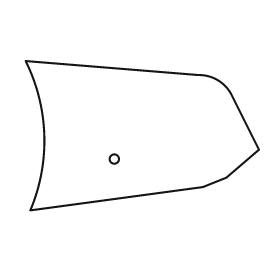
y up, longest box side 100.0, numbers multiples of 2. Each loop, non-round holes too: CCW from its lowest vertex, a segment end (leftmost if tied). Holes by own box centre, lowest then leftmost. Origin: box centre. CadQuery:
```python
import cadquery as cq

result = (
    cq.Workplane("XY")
    .moveTo(-48.0, -32.0)
    .lineTo(26.0, -22.0)
    .lineTo(36.0, -18.0)
    .lineTo(50.0, -6.0)
    .lineTo(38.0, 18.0)
    .threePointArc((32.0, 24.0), (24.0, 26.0))
    .lineTo(-50.0, 32.0)
    .threePointArc((-42.0, 0.0), (-48.0, -32.0))
    .close()
    .moveTo(-12.0, -10.0)
    .circle(2.0)
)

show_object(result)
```